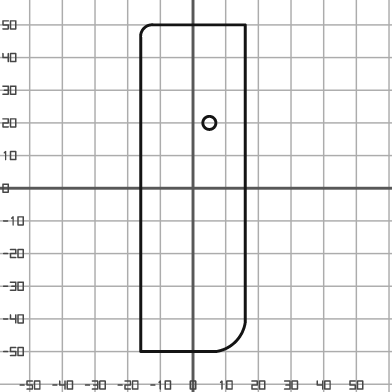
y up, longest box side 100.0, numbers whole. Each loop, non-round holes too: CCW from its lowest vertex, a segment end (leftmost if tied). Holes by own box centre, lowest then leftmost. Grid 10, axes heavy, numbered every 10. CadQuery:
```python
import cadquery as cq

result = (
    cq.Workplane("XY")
    .moveTo(-16.0, -50.0)
    .lineTo(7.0, -50.0)
    .threePointArc((13.0, -47.0), (16.0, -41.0))
    .lineTo(16.0, 50.0)
    .lineTo(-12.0, 50.0)
    .threePointArc((-15.0, 49.0), (-16.0, 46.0))
    .close()
    .moveTo(5.0, 20.0)
    .circle(2.0)
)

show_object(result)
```